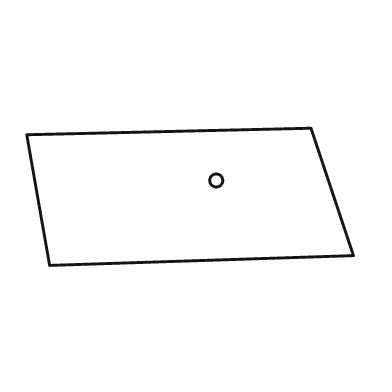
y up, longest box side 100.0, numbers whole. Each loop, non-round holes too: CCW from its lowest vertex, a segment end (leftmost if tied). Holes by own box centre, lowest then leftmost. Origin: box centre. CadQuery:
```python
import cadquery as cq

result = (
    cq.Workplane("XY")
    .moveTo(-43.0, -21.0)
    .lineTo(50.0, -18.0)
    .lineTo(37.0, 21.0)
    .lineTo(-50.0, 19.0)
    .close()
    .moveTo(8.0, 5.0)
    .circle(2.0)
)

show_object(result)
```